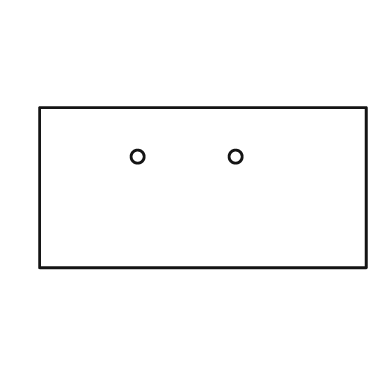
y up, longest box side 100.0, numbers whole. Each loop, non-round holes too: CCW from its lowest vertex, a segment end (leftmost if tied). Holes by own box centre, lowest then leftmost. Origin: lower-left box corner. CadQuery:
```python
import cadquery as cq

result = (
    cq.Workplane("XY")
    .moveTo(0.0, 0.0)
    .lineTo(100.0, 0.0)
    .lineTo(100.0, 49.0)
    .lineTo(0.0, 49.0)
    .close()
    .moveTo(30.0, 34.0)
    .circle(2.0)
    .moveTo(60.0, 34.0)
    .circle(2.0)
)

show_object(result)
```